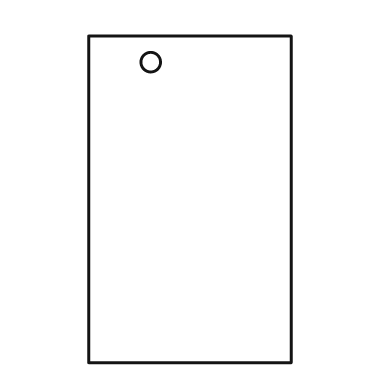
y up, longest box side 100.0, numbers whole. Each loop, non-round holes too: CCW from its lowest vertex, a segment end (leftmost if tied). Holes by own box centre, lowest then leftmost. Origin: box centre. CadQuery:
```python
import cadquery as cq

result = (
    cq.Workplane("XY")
    .moveTo(-31.0, -50.0)
    .lineTo(31.0, -50.0)
    .lineTo(31.0, 50.0)
    .lineTo(-31.0, 50.0)
    .close()
    .moveTo(-12.0, 42.0)
    .circle(3.0)
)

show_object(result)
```